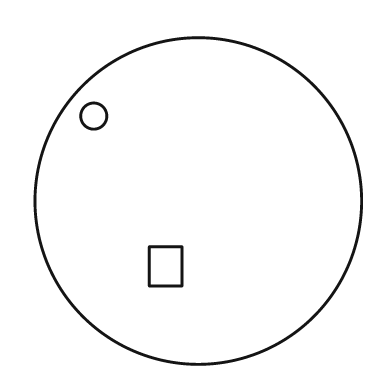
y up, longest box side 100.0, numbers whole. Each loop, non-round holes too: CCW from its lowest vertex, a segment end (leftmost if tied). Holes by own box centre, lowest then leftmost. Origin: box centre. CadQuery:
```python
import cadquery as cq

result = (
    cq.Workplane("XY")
    .moveTo(0.0, 0.0)
    .circle(50.0)
    .moveTo(-15.0, -26.0)
    .lineTo(-5.0, -26.0)
    .lineTo(-5.0, -14.0)
    .lineTo(-15.0, -14.0)
    .close()
    .moveTo(-32.0, 26.0)
    .circle(4.0)
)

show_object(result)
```